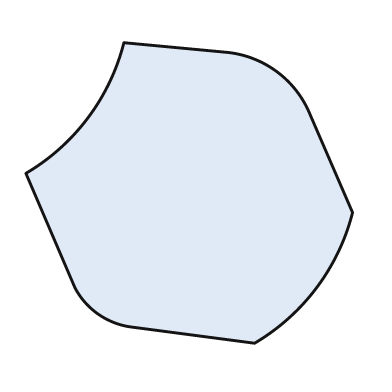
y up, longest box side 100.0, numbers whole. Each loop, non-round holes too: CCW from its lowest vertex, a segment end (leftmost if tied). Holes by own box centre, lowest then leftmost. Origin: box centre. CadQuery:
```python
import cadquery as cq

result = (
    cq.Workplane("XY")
    .moveTo(20.0, -46.0)
    .threePointArc((39.0, -29.0), (50.0, -6.0))
    .lineTo(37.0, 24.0)
    .threePointArc((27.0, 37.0), (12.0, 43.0))
    .lineTo(-20.0, 46.0)
    .threePointArc((-31.0, 23.0), (-50.0, 6.0))
    .lineTo(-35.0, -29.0)
    .threePointArc((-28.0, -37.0), (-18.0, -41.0))
    .close()
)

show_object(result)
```